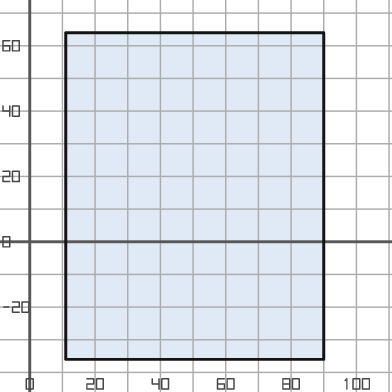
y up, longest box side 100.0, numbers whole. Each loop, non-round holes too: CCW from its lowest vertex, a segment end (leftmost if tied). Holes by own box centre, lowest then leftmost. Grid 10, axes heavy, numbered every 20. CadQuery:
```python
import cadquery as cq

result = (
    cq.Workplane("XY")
    .moveTo(11.0, -36.0)
    .lineTo(90.0, -36.0)
    .lineTo(90.0, 64.0)
    .lineTo(11.0, 64.0)
    .close()
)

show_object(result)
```